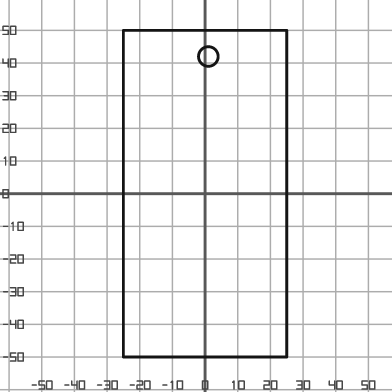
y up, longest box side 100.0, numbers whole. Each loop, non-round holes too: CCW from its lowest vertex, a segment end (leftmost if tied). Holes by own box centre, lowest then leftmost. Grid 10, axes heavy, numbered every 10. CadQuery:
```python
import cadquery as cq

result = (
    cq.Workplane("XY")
    .moveTo(-25.0, -50.0)
    .lineTo(25.0, -50.0)
    .lineTo(25.0, 50.0)
    .lineTo(-25.0, 50.0)
    .close()
    .moveTo(1.0, 42.0)
    .circle(3.0)
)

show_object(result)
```